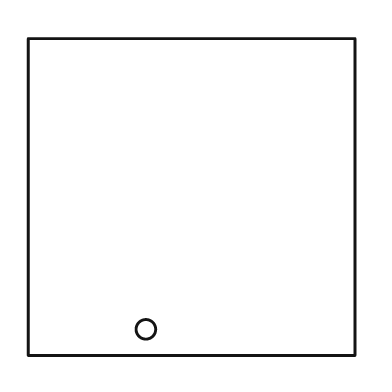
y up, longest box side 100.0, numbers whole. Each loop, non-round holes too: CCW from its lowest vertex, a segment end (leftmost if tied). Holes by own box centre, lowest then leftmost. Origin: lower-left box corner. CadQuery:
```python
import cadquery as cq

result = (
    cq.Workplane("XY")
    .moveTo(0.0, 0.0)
    .lineTo(100.0, 0.0)
    .lineTo(100.0, 97.0)
    .lineTo(0.0, 97.0)
    .close()
    .moveTo(36.0, 8.0)
    .circle(3.0)
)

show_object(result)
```